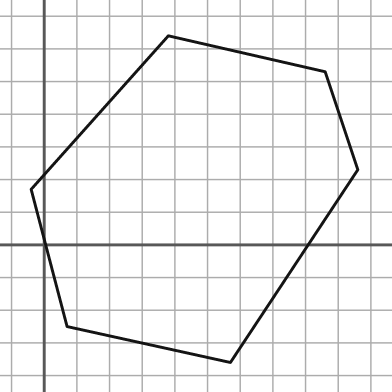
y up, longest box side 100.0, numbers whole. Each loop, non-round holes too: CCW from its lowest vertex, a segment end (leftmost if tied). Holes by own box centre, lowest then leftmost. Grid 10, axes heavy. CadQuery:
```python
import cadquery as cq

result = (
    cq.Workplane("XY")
    .moveTo(57.0, -36.0)
    .lineTo(96.0, 23.0)
    .lineTo(86.0, 53.0)
    .lineTo(38.0, 64.0)
    .lineTo(-4.0, 17.0)
    .lineTo(7.0, -25.0)
    .close()
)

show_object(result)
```